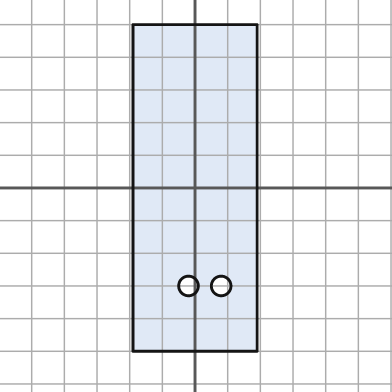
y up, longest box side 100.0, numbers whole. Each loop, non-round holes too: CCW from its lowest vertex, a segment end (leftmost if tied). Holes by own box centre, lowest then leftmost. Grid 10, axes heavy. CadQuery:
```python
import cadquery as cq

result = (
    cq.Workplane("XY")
    .moveTo(-19.0, -50.0)
    .lineTo(19.0, -50.0)
    .lineTo(19.0, 50.0)
    .lineTo(-19.0, 50.0)
    .close()
    .moveTo(-2.0, -30.0)
    .circle(3.0)
    .moveTo(8.0, -30.0)
    .circle(3.0)
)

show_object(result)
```